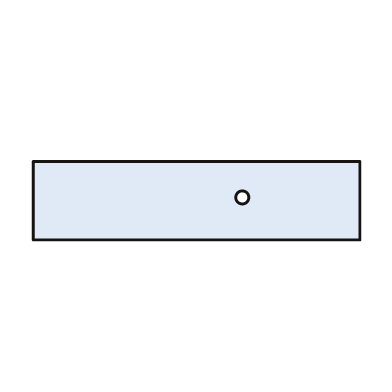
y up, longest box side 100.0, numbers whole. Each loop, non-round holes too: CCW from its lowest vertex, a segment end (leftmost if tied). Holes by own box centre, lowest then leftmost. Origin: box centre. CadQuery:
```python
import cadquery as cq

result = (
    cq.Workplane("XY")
    .moveTo(-50.0, -12.0)
    .lineTo(50.0, -12.0)
    .lineTo(50.0, 12.0)
    .lineTo(-50.0, 12.0)
    .close()
    .moveTo(14.0, 1.0)
    .circle(2.0)
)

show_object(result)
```